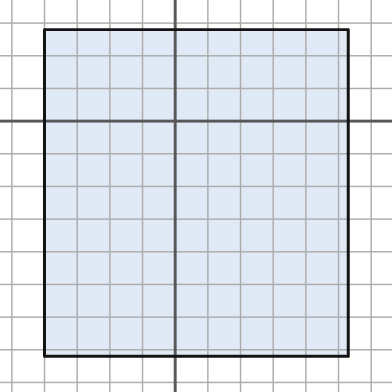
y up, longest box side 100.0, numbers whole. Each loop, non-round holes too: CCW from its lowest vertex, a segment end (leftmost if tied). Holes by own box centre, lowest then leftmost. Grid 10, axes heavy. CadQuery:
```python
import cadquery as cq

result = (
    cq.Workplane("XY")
    .moveTo(-40.0, -72.0)
    .lineTo(53.0, -72.0)
    .lineTo(53.0, 28.0)
    .lineTo(-40.0, 28.0)
    .close()
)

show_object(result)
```